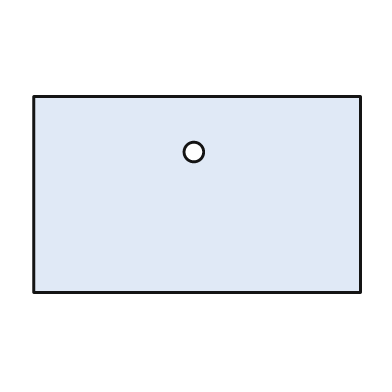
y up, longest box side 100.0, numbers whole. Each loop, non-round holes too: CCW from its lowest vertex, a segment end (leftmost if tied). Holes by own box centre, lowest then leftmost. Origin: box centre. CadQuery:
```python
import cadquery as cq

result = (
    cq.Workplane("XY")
    .moveTo(-50.0, -30.0)
    .lineTo(50.0, -30.0)
    .lineTo(50.0, 30.0)
    .lineTo(-50.0, 30.0)
    .close()
    .moveTo(-1.0, 13.0)
    .circle(3.0)
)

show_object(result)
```